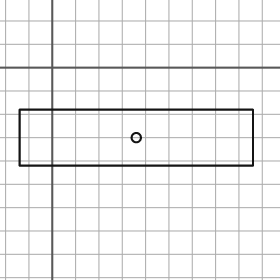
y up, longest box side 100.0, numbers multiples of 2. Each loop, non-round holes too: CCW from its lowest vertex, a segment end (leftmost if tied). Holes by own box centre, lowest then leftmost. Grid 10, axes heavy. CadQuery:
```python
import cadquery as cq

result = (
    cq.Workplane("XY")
    .moveTo(-14.0, -42.0)
    .lineTo(86.0, -42.0)
    .lineTo(86.0, -18.0)
    .lineTo(-14.0, -18.0)
    .close()
    .moveTo(36.0, -30.0)
    .circle(2.0)
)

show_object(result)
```